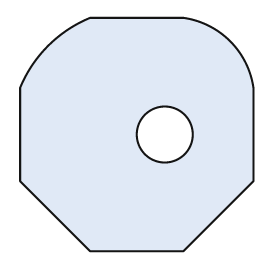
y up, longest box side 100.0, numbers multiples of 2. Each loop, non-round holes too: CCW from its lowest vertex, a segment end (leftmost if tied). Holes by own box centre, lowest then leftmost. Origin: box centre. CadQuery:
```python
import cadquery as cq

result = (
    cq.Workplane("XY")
    .moveTo(-20.0, -50.0)
    .lineTo(20.0, -50.0)
    .lineTo(50.0, -20.0)
    .lineTo(50.0, 20.0)
    .threePointArc((40.0, 40.0), (20.0, 50.0))
    .lineTo(-20.0, 50.0)
    .threePointArc((-38.0, 38.0), (-50.0, 20.0))
    .lineTo(-50.0, -20.0)
    .close()
    .moveTo(12.0, 0.0)
    .circle(12.0)
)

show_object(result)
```